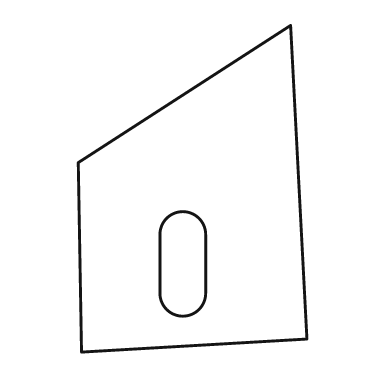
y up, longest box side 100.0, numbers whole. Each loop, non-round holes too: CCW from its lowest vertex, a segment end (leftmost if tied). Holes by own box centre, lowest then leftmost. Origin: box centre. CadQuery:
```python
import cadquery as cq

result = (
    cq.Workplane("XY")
    .moveTo(-34.0, -50.0)
    .lineTo(35.0, -46.0)
    .lineTo(30.0, 50.0)
    .lineTo(-35.0, 8.0)
    .close()
    .moveTo(-10.0, -32.0)
    .threePointArc((-3.0, -39.0), (4.0, -32.0))
    .lineTo(4.0, -14.0)
    .threePointArc((-3.0, -7.0), (-10.0, -14.0))
    .close()
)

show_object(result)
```